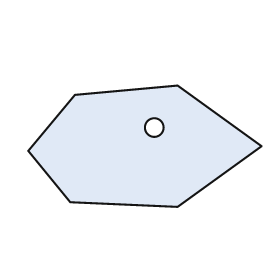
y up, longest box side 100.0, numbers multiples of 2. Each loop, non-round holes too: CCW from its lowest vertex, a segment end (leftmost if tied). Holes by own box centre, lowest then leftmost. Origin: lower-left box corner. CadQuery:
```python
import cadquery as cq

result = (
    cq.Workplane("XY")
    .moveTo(64.0, 0.0)
    .lineTo(100.0, 26.0)
    .lineTo(64.0, 52.0)
    .lineTo(20.0, 48.0)
    .lineTo(0.0, 24.0)
    .lineTo(18.0, 2.0)
    .close()
    .moveTo(54.0, 34.0)
    .circle(4.0)
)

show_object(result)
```